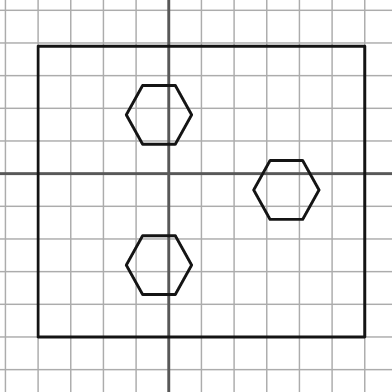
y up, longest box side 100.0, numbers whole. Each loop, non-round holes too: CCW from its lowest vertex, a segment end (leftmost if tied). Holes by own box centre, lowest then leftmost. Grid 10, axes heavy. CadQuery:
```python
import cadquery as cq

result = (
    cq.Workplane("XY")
    .moveTo(-40.0, -50.0)
    .lineTo(60.0, -50.0)
    .lineTo(60.0, 39.0)
    .lineTo(-40.0, 39.0)
    .close()
    .moveTo(-8.0, -37.0)
    .lineTo(2.0, -37.0)
    .lineTo(7.0, -28.0)
    .lineTo(2.0, -19.0)
    .lineTo(-8.0, -19.0)
    .lineTo(-13.0, -28.0)
    .close()
    .moveTo(31.0, -14.0)
    .lineTo(41.0, -14.0)
    .lineTo(46.0, -5.0)
    .lineTo(41.0, 4.0)
    .lineTo(31.0, 4.0)
    .lineTo(26.0, -5.0)
    .close()
    .moveTo(-8.0, 9.0)
    .lineTo(2.0, 9.0)
    .lineTo(7.0, 18.0)
    .lineTo(2.0, 27.0)
    .lineTo(-8.0, 27.0)
    .lineTo(-13.0, 18.0)
    .close()
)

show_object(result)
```